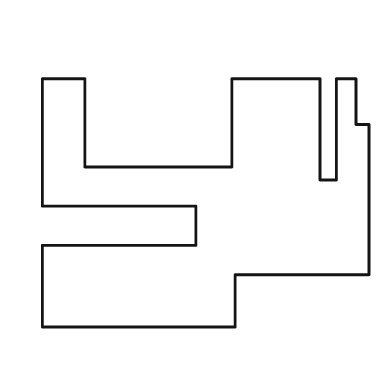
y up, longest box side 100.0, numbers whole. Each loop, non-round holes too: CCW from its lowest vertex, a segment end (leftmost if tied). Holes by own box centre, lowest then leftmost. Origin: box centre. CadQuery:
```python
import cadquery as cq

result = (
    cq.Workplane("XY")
    .moveTo(-50.0, -38.0)
    .lineTo(9.0, -38.0)
    .lineTo(9.0, -22.0)
    .lineTo(50.0, -22.0)
    .lineTo(50.0, 24.0)
    .lineTo(46.0, 24.0)
    .lineTo(46.0, 38.0)
    .lineTo(40.0, 38.0)
    .lineTo(40.0, 7.0)
    .lineTo(35.0, 7.0)
    .lineTo(35.0, 38.0)
    .lineTo(8.0, 38.0)
    .lineTo(8.0, 11.0)
    .lineTo(-37.0, 11.0)
    .lineTo(-37.0, 38.0)
    .lineTo(-50.0, 38.0)
    .lineTo(-50.0, -1.0)
    .lineTo(-3.0, -1.0)
    .lineTo(-3.0, -13.0)
    .lineTo(-50.0, -13.0)
    .close()
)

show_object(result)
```